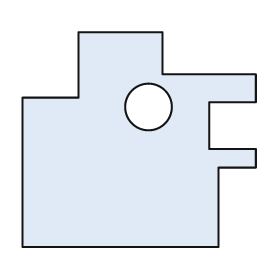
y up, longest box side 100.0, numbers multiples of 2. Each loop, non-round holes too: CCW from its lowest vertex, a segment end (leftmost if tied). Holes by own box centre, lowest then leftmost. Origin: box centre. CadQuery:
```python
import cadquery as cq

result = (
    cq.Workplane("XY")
    .moveTo(-50.0, -46.0)
    .lineTo(34.0, -46.0)
    .lineTo(34.0, -12.0)
    .lineTo(50.0, -12.0)
    .lineTo(50.0, -4.0)
    .lineTo(30.0, -4.0)
    .lineTo(30.0, 16.0)
    .lineTo(50.0, 16.0)
    .lineTo(50.0, 28.0)
    .lineTo(10.0, 28.0)
    .lineTo(10.0, 46.0)
    .lineTo(-26.0, 46.0)
    .lineTo(-26.0, 18.0)
    .lineTo(-50.0, 18.0)
    .close()
    .moveTo(4.0, 14.0)
    .circle(10.0)
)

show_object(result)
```